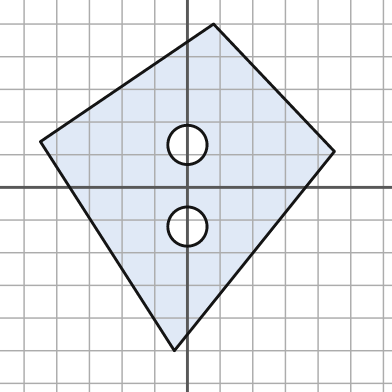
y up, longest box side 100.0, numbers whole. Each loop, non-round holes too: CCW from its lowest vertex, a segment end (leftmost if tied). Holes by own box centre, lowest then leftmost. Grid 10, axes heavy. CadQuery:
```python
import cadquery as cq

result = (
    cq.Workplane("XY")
    .moveTo(-4.0, -50.0)
    .lineTo(45.0, 11.0)
    .lineTo(8.0, 50.0)
    .lineTo(-45.0, 14.0)
    .close()
    .moveTo(0.0, -12.0)
    .circle(6.0)
    .moveTo(0.0, 13.0)
    .circle(6.0)
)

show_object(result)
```